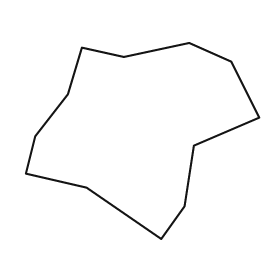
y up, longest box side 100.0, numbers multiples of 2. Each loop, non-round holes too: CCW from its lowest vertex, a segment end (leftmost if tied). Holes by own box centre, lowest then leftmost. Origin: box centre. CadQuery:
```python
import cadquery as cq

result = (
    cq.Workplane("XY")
    .moveTo(8.0, -42.0)
    .lineTo(18.0, -28.0)
    .lineTo(22.0, -2.0)
    .lineTo(50.0, 10.0)
    .lineTo(38.0, 34.0)
    .lineTo(20.0, 42.0)
    .lineTo(-8.0, 36.0)
    .lineTo(-26.0, 40.0)
    .lineTo(-32.0, 20.0)
    .lineTo(-46.0, 2.0)
    .lineTo(-50.0, -14.0)
    .lineTo(-24.0, -20.0)
    .close()
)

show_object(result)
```